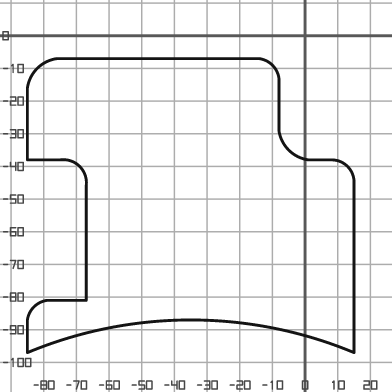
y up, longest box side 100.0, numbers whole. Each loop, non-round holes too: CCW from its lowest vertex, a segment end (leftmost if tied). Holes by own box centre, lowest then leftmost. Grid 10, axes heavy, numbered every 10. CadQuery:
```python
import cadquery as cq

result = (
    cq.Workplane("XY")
    .moveTo(-85.0, -97.0)
    .threePointArc((-35.0, -87.0), (15.0, -97.0))
    .lineTo(15.0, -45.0)
    .threePointArc((13.0, -40.0), (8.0, -38.0))
    .lineTo(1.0, -38.0)
    .threePointArc((-5.0, -35.0), (-8.0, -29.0))
    .lineTo(-8.0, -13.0)
    .threePointArc((-10.0, -9.0), (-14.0, -7.0))
    .lineTo(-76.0, -7.0)
    .threePointArc((-82.0, -10.0), (-85.0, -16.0))
    .lineTo(-85.0, -38.0)
    .lineTo(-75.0, -38.0)
    .threePointArc((-69.0, -40.0), (-67.0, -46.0))
    .lineTo(-67.0, -81.0)
    .lineTo(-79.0, -81.0)
    .threePointArc((-83.0, -83.0), (-85.0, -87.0))
    .close()
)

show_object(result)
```